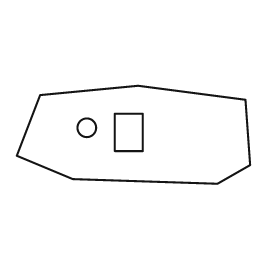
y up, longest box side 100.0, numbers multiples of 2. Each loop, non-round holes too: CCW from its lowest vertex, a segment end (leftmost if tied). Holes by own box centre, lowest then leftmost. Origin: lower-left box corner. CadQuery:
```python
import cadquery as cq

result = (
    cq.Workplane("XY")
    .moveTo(86.0, 0.0)
    .lineTo(100.0, 8.0)
    .lineTo(98.0, 36.0)
    .lineTo(52.0, 42.0)
    .lineTo(10.0, 38.0)
    .lineTo(0.0, 12.0)
    .lineTo(24.0, 2.0)
    .close()
    .moveTo(42.0, 14.0)
    .lineTo(54.0, 14.0)
    .lineTo(54.0, 30.0)
    .lineTo(42.0, 30.0)
    .close()
    .moveTo(30.0, 24.0)
    .circle(4.0)
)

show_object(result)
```